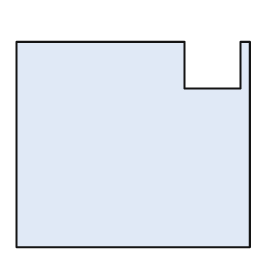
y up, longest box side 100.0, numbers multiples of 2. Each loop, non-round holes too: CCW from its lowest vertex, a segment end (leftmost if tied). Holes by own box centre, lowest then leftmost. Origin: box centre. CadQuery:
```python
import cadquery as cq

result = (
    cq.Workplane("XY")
    .moveTo(-50.0, -44.0)
    .lineTo(50.0, -44.0)
    .lineTo(50.0, 44.0)
    .lineTo(46.0, 44.0)
    .lineTo(46.0, 24.0)
    .lineTo(22.0, 24.0)
    .lineTo(22.0, 44.0)
    .lineTo(-50.0, 44.0)
    .close()
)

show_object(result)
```